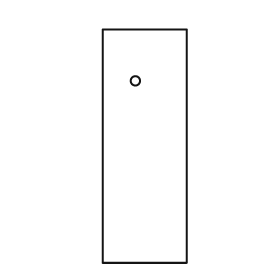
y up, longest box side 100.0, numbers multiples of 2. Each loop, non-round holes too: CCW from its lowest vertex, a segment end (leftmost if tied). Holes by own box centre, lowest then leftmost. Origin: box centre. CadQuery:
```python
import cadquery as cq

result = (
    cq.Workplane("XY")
    .moveTo(-18.0, -50.0)
    .lineTo(18.0, -50.0)
    .lineTo(18.0, 50.0)
    .lineTo(-18.0, 50.0)
    .close()
    .moveTo(-4.0, 28.0)
    .circle(2.0)
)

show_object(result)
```